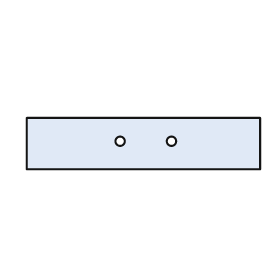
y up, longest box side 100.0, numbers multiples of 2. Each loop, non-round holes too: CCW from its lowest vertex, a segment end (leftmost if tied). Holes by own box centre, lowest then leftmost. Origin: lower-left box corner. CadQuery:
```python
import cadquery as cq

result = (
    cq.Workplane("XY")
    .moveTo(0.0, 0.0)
    .lineTo(100.0, 0.0)
    .lineTo(100.0, 22.0)
    .lineTo(0.0, 22.0)
    .close()
    .moveTo(40.0, 12.0)
    .circle(2.0)
    .moveTo(62.0, 12.0)
    .circle(2.0)
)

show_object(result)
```